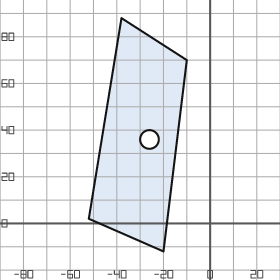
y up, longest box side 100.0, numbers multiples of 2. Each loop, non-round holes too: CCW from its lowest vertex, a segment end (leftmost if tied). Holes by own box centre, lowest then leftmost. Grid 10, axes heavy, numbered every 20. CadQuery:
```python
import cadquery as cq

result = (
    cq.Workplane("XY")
    .moveTo(-20.0, -12.0)
    .lineTo(-10.0, 70.0)
    .lineTo(-38.0, 88.0)
    .lineTo(-52.0, 2.0)
    .close()
    .moveTo(-26.0, 36.0)
    .circle(4.0)
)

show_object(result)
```